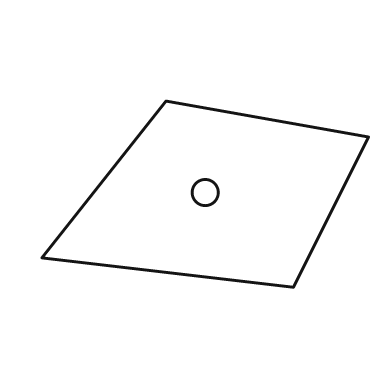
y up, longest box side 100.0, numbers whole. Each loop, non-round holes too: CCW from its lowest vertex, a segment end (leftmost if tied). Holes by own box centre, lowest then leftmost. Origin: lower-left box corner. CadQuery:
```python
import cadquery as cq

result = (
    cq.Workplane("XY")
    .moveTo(77.0, 0.0)
    .lineTo(100.0, 46.0)
    .lineTo(38.0, 57.0)
    .lineTo(0.0, 9.0)
    .close()
    .moveTo(50.0, 29.0)
    .circle(4.0)
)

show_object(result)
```